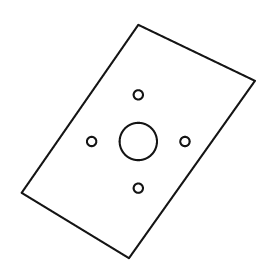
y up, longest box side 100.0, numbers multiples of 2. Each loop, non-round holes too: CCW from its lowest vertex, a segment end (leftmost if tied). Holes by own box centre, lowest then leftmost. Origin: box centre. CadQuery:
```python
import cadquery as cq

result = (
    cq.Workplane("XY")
    .moveTo(-4.0, -50.0)
    .lineTo(50.0, 26.0)
    .lineTo(0.0, 50.0)
    .lineTo(-50.0, -22.0)
    .close()
    .moveTo(0.0, -20.0)
    .circle(2.0)
    .moveTo(-20.0, 0.0)
    .circle(2.0)
    .moveTo(0.0, 0.0)
    .circle(8.0)
    .moveTo(20.0, 0.0)
    .circle(2.0)
    .moveTo(0.0, 20.0)
    .circle(2.0)
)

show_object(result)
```